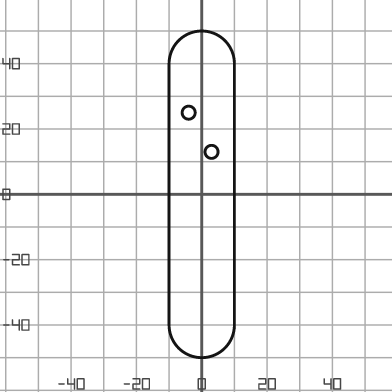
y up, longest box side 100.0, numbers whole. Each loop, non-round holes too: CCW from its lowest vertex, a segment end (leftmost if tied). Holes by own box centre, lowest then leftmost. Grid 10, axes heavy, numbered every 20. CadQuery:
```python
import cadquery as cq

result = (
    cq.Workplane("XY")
    .moveTo(-10.0, -40.0)
    .threePointArc((0.0, -50.0), (10.0, -40.0))
    .lineTo(10.0, 40.0)
    .threePointArc((0.0, 50.0), (-10.0, 40.0))
    .close()
    .moveTo(3.0, 13.0)
    .circle(2.0)
    .moveTo(-4.0, 25.0)
    .circle(2.0)
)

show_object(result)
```